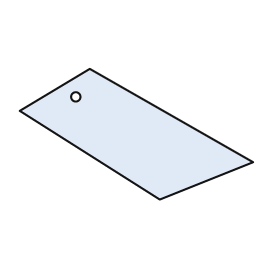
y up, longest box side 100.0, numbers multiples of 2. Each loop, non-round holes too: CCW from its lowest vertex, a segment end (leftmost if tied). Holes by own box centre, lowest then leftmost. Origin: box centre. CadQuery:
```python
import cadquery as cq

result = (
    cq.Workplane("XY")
    .moveTo(10.0, -28.0)
    .lineTo(50.0, -12.0)
    .lineTo(-20.0, 28.0)
    .lineTo(-50.0, 10.0)
    .close()
    .moveTo(-26.0, 16.0)
    .circle(2.0)
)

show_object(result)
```